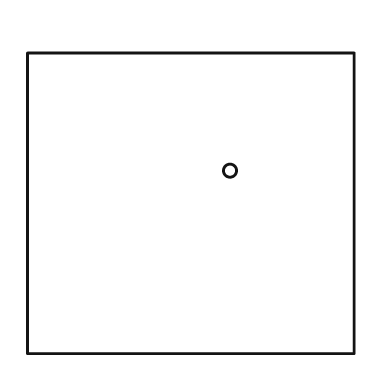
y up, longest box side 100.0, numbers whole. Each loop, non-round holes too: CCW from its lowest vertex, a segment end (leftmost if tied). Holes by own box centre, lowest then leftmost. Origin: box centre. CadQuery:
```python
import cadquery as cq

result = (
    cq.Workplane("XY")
    .moveTo(-50.0, -46.0)
    .lineTo(50.0, -46.0)
    .lineTo(50.0, 46.0)
    .lineTo(-50.0, 46.0)
    .close()
    .moveTo(12.0, 10.0)
    .circle(2.0)
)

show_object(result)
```